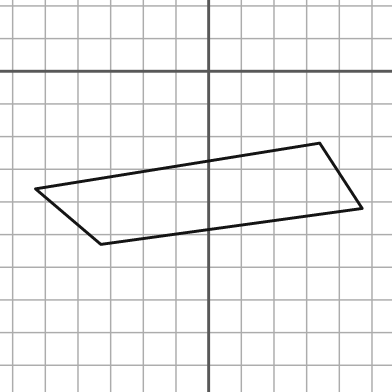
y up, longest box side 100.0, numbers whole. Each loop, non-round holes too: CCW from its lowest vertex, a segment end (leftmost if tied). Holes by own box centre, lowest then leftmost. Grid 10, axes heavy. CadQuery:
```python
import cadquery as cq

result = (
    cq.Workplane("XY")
    .moveTo(-33.0, -53.0)
    .lineTo(47.0, -42.0)
    .lineTo(34.0, -22.0)
    .lineTo(-53.0, -36.0)
    .close()
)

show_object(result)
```